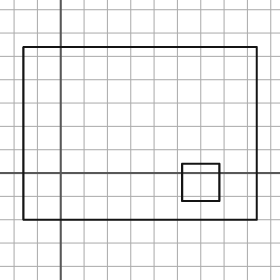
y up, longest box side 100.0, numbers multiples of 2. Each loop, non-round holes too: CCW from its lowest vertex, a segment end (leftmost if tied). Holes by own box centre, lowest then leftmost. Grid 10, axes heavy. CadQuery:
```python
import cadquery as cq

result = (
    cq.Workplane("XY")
    .moveTo(-16.0, -20.0)
    .lineTo(84.0, -20.0)
    .lineTo(84.0, 54.0)
    .lineTo(-16.0, 54.0)
    .close()
    .moveTo(52.0, -12.0)
    .lineTo(68.0, -12.0)
    .lineTo(68.0, 4.0)
    .lineTo(52.0, 4.0)
    .close()
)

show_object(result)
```